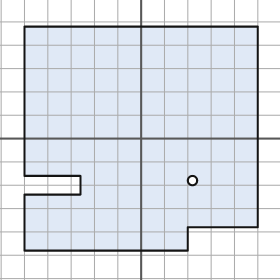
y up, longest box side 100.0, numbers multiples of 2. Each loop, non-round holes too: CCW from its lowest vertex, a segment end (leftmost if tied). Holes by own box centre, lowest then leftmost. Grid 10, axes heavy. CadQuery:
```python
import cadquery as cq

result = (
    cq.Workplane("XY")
    .moveTo(-50.0, -48.0)
    .lineTo(20.0, -48.0)
    .lineTo(20.0, -38.0)
    .lineTo(50.0, -38.0)
    .lineTo(50.0, 48.0)
    .lineTo(-50.0, 48.0)
    .lineTo(-50.0, -16.0)
    .lineTo(-26.0, -16.0)
    .lineTo(-26.0, -24.0)
    .lineTo(-50.0, -24.0)
    .close()
    .moveTo(22.0, -18.0)
    .circle(2.0)
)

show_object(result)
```